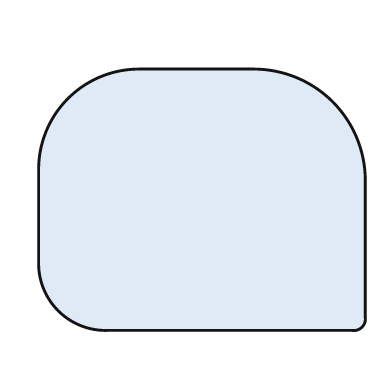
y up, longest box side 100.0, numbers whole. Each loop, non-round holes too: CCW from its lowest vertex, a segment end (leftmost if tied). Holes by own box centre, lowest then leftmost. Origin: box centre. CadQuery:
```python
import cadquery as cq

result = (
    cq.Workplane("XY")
    .moveTo(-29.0, -40.0)
    .lineTo(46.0, -40.0)
    .threePointArc((49.0, -39.0), (50.0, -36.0))
    .lineTo(50.0, 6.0)
    .threePointArc((40.0, 30.0), (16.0, 40.0))
    .lineTo(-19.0, 40.0)
    .threePointArc((-41.0, 31.0), (-50.0, 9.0))
    .lineTo(-50.0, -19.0)
    .threePointArc((-44.0, -34.0), (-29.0, -40.0))
    .close()
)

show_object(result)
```